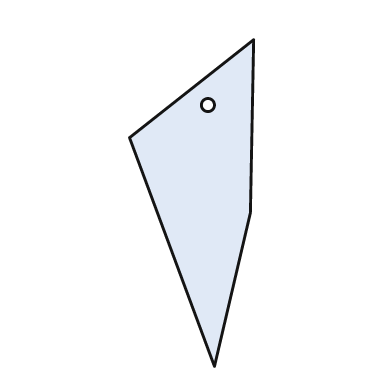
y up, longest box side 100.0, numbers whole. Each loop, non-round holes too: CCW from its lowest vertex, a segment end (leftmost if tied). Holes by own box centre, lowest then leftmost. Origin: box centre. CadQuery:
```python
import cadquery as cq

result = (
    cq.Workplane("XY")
    .moveTo(7.0, -50.0)
    .lineTo(18.0, -3.0)
    .lineTo(19.0, 50.0)
    .lineTo(-19.0, 20.0)
    .close()
    .moveTo(5.0, 30.0)
    .circle(2.0)
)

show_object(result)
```